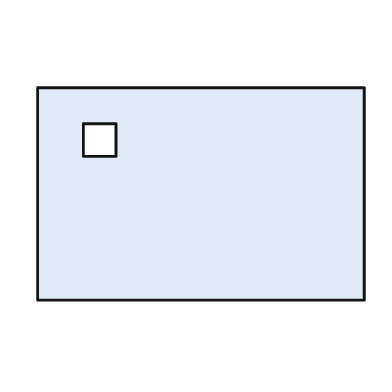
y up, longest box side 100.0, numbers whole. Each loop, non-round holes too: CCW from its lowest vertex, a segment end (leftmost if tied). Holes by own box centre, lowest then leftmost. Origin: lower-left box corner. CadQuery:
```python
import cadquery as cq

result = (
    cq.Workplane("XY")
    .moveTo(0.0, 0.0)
    .lineTo(100.0, 0.0)
    .lineTo(100.0, 65.0)
    .lineTo(0.0, 65.0)
    .close()
    .moveTo(14.0, 44.0)
    .lineTo(24.0, 44.0)
    .lineTo(24.0, 54.0)
    .lineTo(14.0, 54.0)
    .close()
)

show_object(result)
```